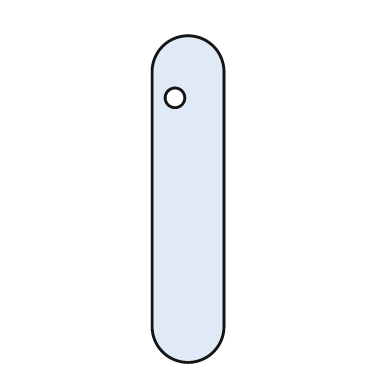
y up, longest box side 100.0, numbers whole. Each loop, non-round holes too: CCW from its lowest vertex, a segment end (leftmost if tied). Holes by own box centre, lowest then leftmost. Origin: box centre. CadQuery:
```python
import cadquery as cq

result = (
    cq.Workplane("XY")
    .moveTo(-11.0, -39.0)
    .threePointArc((0.0, -50.0), (11.0, -39.0))
    .lineTo(11.0, 39.0)
    .threePointArc((0.0, 50.0), (-11.0, 39.0))
    .close()
    .moveTo(-4.0, 31.0)
    .circle(3.0)
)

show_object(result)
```